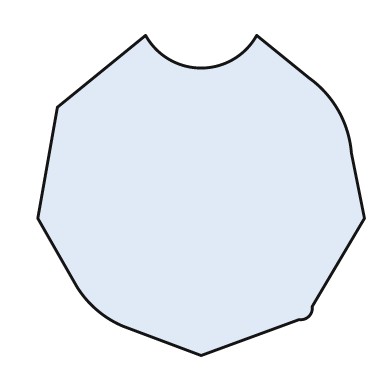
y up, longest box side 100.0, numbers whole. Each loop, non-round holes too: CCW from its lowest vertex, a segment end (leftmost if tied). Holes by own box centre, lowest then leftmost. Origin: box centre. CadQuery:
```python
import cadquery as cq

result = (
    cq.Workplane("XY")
    .moveTo(0.0, -49.0)
    .lineTo(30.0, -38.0)
    .threePointArc((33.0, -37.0), (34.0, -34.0))
    .lineTo(50.0, -7.0)
    .lineTo(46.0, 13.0)
    .threePointArc((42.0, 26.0), (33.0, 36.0))
    .lineTo(17.0, 49.0)
    .threePointArc((0.0, 39.0), (-17.0, 49.0))
    .lineTo(-44.0, 27.0)
    .lineTo(-50.0, -7.0)
    .lineTo(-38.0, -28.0)
    .threePointArc((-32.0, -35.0), (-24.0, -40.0))
    .close()
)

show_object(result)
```